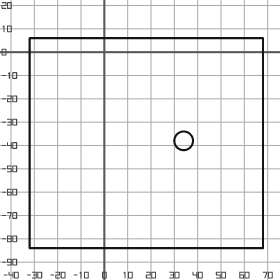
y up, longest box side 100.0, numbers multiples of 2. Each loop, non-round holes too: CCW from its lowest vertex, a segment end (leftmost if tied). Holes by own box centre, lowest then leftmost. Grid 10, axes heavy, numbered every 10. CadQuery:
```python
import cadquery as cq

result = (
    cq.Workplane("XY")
    .moveTo(-32.0, -84.0)
    .lineTo(68.0, -84.0)
    .lineTo(68.0, 6.0)
    .lineTo(-32.0, 6.0)
    .close()
    .moveTo(34.0, -38.0)
    .circle(4.0)
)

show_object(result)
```